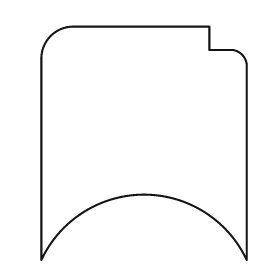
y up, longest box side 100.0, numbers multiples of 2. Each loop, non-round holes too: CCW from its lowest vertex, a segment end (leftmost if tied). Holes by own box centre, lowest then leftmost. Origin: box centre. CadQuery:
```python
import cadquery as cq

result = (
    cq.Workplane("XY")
    .moveTo(-44.0, -50.0)
    .threePointArc((0.0, -22.0), (44.0, -50.0))
    .lineTo(44.0, 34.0)
    .threePointArc((42.0, 38.0), (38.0, 40.0))
    .lineTo(28.0, 40.0)
    .lineTo(28.0, 50.0)
    .lineTo(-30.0, 50.0)
    .threePointArc((-40.0, 46.0), (-44.0, 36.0))
    .close()
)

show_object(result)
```